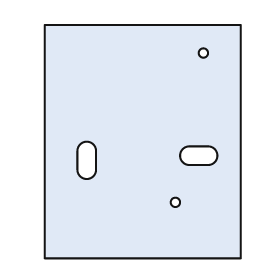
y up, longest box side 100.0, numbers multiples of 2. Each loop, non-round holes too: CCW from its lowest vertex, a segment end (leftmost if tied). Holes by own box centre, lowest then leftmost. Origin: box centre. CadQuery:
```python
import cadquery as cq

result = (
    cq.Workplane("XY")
    .moveTo(-42.0, -50.0)
    .lineTo(42.0, -50.0)
    .lineTo(42.0, 50.0)
    .lineTo(-42.0, 50.0)
    .close()
    .moveTo(14.0, -26.0)
    .circle(2.0)
    .moveTo(-28.0, -12.0)
    .threePointArc((-24.0, -16.0), (-20.0, -12.0))
    .lineTo(-20.0, -4.0)
    .threePointArc((-24.0, 0.0), (-28.0, -4.0))
    .close()
    .moveTo(20.0, -10.0)
    .lineTo(28.0, -10.0)
    .threePointArc((32.0, -6.0), (28.0, -2.0))
    .lineTo(20.0, -2.0)
    .threePointArc((16.0, -6.0), (20.0, -10.0))
    .close()
    .moveTo(26.0, 38.0)
    .circle(2.0)
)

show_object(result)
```